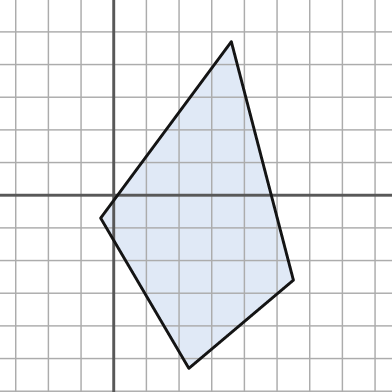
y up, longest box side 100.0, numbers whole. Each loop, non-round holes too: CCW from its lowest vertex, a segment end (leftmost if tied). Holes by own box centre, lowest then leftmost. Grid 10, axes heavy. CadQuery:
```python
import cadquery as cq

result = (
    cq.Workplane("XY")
    .moveTo(23.0, -53.0)
    .lineTo(55.0, -26.0)
    .lineTo(36.0, 47.0)
    .lineTo(-4.0, -7.0)
    .close()
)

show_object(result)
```